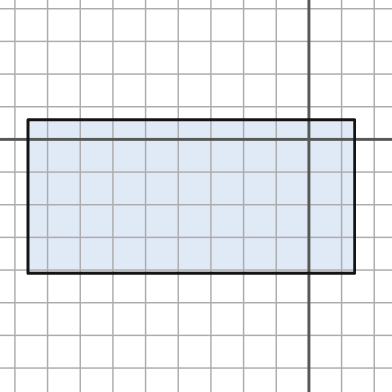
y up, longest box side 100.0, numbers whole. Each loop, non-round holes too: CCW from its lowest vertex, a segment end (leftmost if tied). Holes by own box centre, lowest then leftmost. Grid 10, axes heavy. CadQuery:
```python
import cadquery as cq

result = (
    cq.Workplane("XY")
    .moveTo(-86.0, -41.0)
    .lineTo(14.0, -41.0)
    .lineTo(14.0, 6.0)
    .lineTo(-86.0, 6.0)
    .close()
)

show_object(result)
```